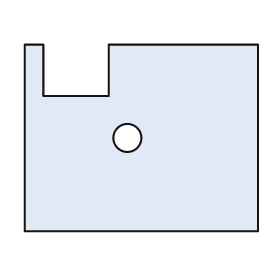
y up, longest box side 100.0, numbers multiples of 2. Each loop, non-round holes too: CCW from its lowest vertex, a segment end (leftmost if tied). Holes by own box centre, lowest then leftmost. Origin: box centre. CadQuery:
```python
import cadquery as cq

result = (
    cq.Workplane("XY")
    .moveTo(-50.0, -40.0)
    .lineTo(50.0, -40.0)
    .lineTo(50.0, 40.0)
    .lineTo(-14.0, 40.0)
    .lineTo(-14.0, 18.0)
    .lineTo(-42.0, 18.0)
    .lineTo(-42.0, 40.0)
    .lineTo(-50.0, 40.0)
    .close()
    .moveTo(-6.0, 0.0)
    .circle(6.0)
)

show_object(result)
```